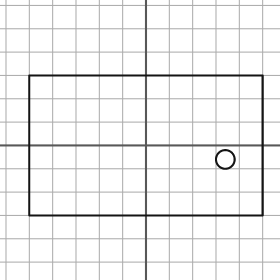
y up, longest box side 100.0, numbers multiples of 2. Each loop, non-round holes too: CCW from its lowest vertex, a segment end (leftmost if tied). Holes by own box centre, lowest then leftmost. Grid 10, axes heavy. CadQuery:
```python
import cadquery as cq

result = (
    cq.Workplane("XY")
    .moveTo(-50.0, -30.0)
    .lineTo(50.0, -30.0)
    .lineTo(50.0, 30.0)
    .lineTo(-50.0, 30.0)
    .close()
    .moveTo(34.0, -6.0)
    .circle(4.0)
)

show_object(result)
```